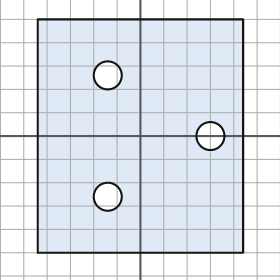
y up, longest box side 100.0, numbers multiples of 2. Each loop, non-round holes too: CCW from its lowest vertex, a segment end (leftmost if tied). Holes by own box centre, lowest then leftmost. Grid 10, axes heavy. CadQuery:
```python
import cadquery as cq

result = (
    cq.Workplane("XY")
    .moveTo(-44.0, -50.0)
    .lineTo(44.0, -50.0)
    .lineTo(44.0, 50.0)
    .lineTo(-44.0, 50.0)
    .close()
    .moveTo(-14.0, -26.0)
    .circle(6.0)
    .moveTo(30.0, 0.0)
    .circle(6.0)
    .moveTo(-14.0, 26.0)
    .circle(6.0)
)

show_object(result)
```